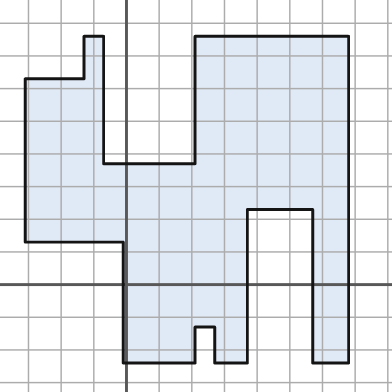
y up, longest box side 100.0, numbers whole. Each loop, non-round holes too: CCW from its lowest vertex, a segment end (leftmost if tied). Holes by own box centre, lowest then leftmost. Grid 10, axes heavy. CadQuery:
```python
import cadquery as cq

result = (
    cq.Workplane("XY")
    .moveTo(-1.0, -24.0)
    .lineTo(21.0, -24.0)
    .lineTo(21.0, -13.0)
    .lineTo(27.0, -13.0)
    .lineTo(27.0, -24.0)
    .lineTo(37.0, -24.0)
    .lineTo(37.0, 23.0)
    .lineTo(57.0, 23.0)
    .lineTo(57.0, -24.0)
    .lineTo(68.0, -24.0)
    .lineTo(68.0, 76.0)
    .lineTo(21.0, 76.0)
    .lineTo(21.0, 37.0)
    .lineTo(-7.0, 37.0)
    .lineTo(-7.0, 76.0)
    .lineTo(-13.0, 76.0)
    .lineTo(-13.0, 63.0)
    .lineTo(-31.0, 63.0)
    .lineTo(-31.0, 13.0)
    .lineTo(-1.0, 13.0)
    .close()
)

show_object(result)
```